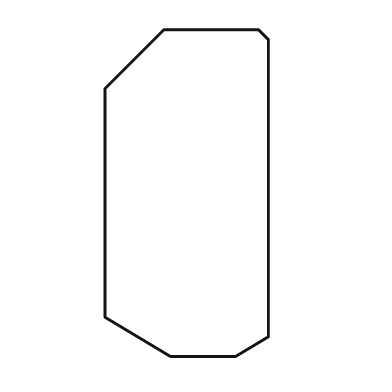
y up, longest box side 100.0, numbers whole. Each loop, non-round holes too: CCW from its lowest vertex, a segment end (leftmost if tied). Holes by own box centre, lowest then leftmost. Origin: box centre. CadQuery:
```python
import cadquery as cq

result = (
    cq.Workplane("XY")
    .moveTo(-5.0, -50.0)
    .lineTo(15.0, -50.0)
    .lineTo(25.0, -44.0)
    .lineTo(25.0, 47.0)
    .lineTo(22.0, 50.0)
    .lineTo(-7.0, 50.0)
    .lineTo(-25.0, 32.0)
    .lineTo(-25.0, -38.0)
    .close()
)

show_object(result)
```